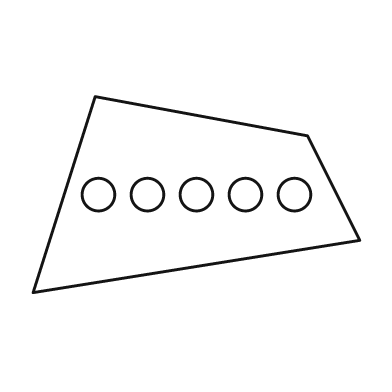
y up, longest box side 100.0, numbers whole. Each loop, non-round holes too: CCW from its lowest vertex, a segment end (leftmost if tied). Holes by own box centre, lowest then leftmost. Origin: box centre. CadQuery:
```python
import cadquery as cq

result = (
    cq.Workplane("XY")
    .moveTo(-50.0, -30.0)
    .lineTo(50.0, -14.0)
    .lineTo(34.0, 18.0)
    .lineTo(-31.0, 30.0)
    .close()
    .moveTo(-30.0, 0.0)
    .circle(5.0)
    .moveTo(-15.0, 0.0)
    .circle(5.0)
    .moveTo(0.0, 0.0)
    .circle(5.0)
    .moveTo(15.0, 0.0)
    .circle(5.0)
    .moveTo(30.0, 0.0)
    .circle(5.0)
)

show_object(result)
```